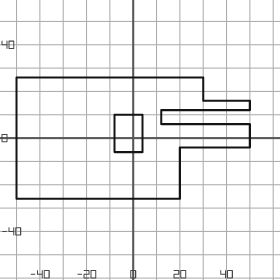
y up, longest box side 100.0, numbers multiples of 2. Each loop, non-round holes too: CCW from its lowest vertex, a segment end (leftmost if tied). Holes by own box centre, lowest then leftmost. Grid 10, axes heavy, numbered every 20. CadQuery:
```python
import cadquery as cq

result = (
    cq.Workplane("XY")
    .moveTo(-50.0, -26.0)
    .lineTo(20.0, -26.0)
    .lineTo(20.0, -4.0)
    .lineTo(50.0, -4.0)
    .lineTo(50.0, 6.0)
    .lineTo(12.0, 6.0)
    .lineTo(12.0, 12.0)
    .lineTo(50.0, 12.0)
    .lineTo(50.0, 16.0)
    .lineTo(30.0, 16.0)
    .lineTo(30.0, 26.0)
    .lineTo(-50.0, 26.0)
    .close()
    .moveTo(-8.0, -6.0)
    .lineTo(4.0, -6.0)
    .lineTo(4.0, 10.0)
    .lineTo(-8.0, 10.0)
    .close()
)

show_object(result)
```